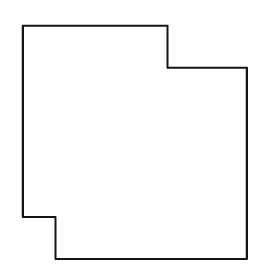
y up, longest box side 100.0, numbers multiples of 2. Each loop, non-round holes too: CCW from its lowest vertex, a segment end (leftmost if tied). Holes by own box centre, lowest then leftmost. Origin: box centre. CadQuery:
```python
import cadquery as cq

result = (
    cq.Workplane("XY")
    .moveTo(-34.0, -50.0)
    .lineTo(48.0, -50.0)
    .lineTo(48.0, 32.0)
    .lineTo(14.0, 32.0)
    .lineTo(14.0, 50.0)
    .lineTo(-48.0, 50.0)
    .lineTo(-48.0, -32.0)
    .lineTo(-34.0, -32.0)
    .close()
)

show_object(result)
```